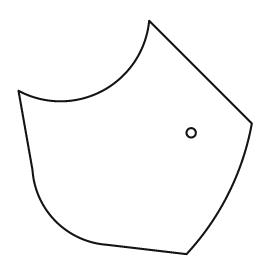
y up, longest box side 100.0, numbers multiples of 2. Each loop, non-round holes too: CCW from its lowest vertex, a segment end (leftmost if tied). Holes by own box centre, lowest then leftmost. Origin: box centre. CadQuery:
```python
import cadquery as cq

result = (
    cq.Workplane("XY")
    .moveTo(22.0, -50.0)
    .threePointArc((40.0, -24.0), (50.0, 6.0))
    .lineTo(6.0, 50.0)
    .threePointArc((-14.0, 20.0), (-50.0, 20.0))
    .lineTo(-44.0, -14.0)
    .threePointArc((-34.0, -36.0), (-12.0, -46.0))
    .close()
    .moveTo(24.0, 2.0)
    .circle(2.0)
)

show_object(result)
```